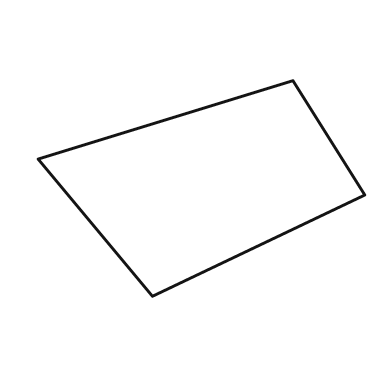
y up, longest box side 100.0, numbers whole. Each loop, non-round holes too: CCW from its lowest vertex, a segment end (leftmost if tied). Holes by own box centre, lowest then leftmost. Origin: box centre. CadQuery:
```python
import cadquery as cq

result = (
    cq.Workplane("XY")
    .moveTo(-15.0, -33.0)
    .lineTo(50.0, -2.0)
    .lineTo(28.0, 33.0)
    .lineTo(-50.0, 9.0)
    .close()
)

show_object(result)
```